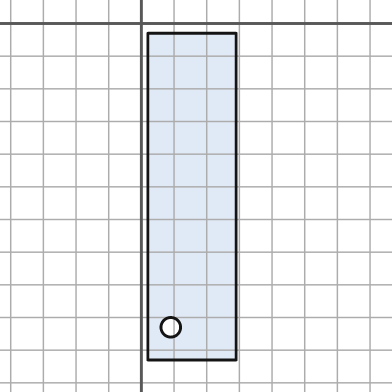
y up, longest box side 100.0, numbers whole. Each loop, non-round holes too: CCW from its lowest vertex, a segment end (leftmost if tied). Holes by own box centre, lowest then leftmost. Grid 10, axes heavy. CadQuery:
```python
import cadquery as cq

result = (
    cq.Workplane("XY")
    .moveTo(2.0, -103.0)
    .lineTo(29.0, -103.0)
    .lineTo(29.0, -3.0)
    .lineTo(2.0, -3.0)
    .close()
    .moveTo(9.0, -93.0)
    .circle(3.0)
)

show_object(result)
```